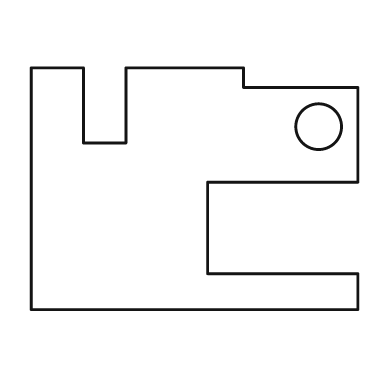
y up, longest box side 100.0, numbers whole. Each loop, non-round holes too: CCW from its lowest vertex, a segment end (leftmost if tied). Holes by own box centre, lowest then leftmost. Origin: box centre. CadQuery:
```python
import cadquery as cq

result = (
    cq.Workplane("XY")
    .moveTo(-50.0, -37.0)
    .lineTo(50.0, -37.0)
    .lineTo(50.0, -26.0)
    .lineTo(4.0, -26.0)
    .lineTo(4.0, 2.0)
    .lineTo(50.0, 2.0)
    .lineTo(50.0, 31.0)
    .lineTo(15.0, 31.0)
    .lineTo(15.0, 37.0)
    .lineTo(-21.0, 37.0)
    .lineTo(-21.0, 14.0)
    .lineTo(-34.0, 14.0)
    .lineTo(-34.0, 37.0)
    .lineTo(-50.0, 37.0)
    .close()
    .moveTo(38.0, 19.0)
    .circle(7.0)
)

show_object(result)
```